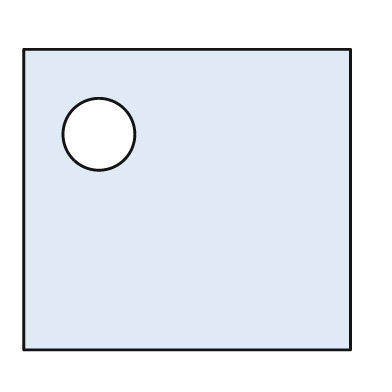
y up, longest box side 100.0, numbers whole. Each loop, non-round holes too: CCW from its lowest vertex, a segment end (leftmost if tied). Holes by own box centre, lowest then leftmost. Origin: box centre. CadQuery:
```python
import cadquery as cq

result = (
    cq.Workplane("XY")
    .moveTo(-50.0, -46.0)
    .lineTo(50.0, -46.0)
    .lineTo(50.0, 46.0)
    .lineTo(-50.0, 46.0)
    .close()
    .moveTo(-27.0, 20.0)
    .circle(11.0)
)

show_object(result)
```